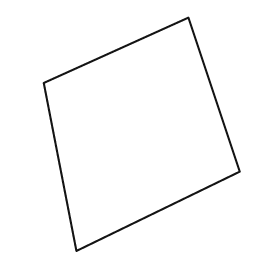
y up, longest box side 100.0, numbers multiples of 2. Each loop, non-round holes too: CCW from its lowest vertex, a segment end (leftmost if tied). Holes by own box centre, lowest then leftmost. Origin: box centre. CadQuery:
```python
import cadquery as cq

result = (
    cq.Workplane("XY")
    .moveTo(-28.0, -50.0)
    .lineTo(42.0, -16.0)
    .lineTo(20.0, 50.0)
    .lineTo(-42.0, 22.0)
    .close()
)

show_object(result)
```